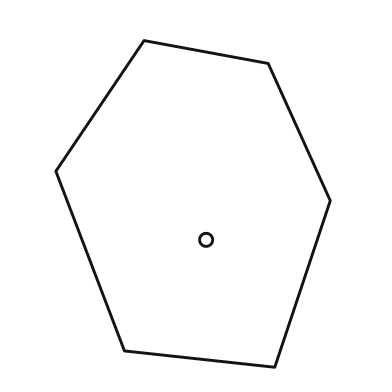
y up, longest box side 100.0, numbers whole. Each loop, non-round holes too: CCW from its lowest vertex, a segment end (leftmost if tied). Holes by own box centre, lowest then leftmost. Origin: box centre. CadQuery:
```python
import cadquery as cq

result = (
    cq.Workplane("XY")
    .moveTo(25.0, -50.0)
    .lineTo(42.0, 1.0)
    .lineTo(23.0, 43.0)
    .lineTo(-15.0, 50.0)
    .lineTo(-42.0, 10.0)
    .lineTo(-21.0, -45.0)
    .close()
    .moveTo(4.0, -11.0)
    .circle(2.0)
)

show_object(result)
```